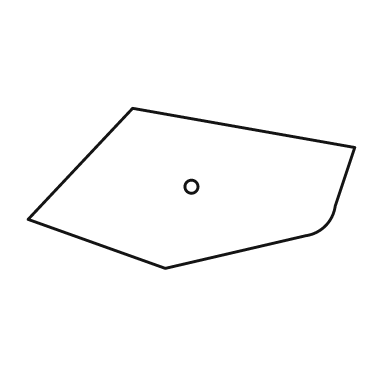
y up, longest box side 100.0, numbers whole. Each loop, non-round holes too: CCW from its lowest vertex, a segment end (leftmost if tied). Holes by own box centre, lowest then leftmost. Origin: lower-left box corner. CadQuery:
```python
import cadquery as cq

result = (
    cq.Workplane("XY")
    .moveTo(42.0, 0.0)
    .lineTo(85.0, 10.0)
    .threePointArc((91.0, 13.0), (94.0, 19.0))
    .lineTo(100.0, 37.0)
    .lineTo(32.0, 49.0)
    .lineTo(0.0, 15.0)
    .close()
    .moveTo(50.0, 25.0)
    .circle(2.0)
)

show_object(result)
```